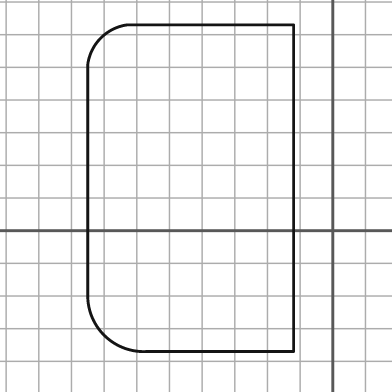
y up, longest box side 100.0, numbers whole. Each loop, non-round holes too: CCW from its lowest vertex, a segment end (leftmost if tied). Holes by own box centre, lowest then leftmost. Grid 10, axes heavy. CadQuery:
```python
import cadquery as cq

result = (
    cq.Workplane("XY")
    .moveTo(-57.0, -37.0)
    .lineTo(-12.0, -37.0)
    .lineTo(-12.0, 63.0)
    .lineTo(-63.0, 63.0)
    .threePointArc((-71.0, 59.0), (-75.0, 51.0))
    .lineTo(-75.0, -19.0)
    .threePointArc((-70.0, -32.0), (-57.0, -37.0))
    .close()
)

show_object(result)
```